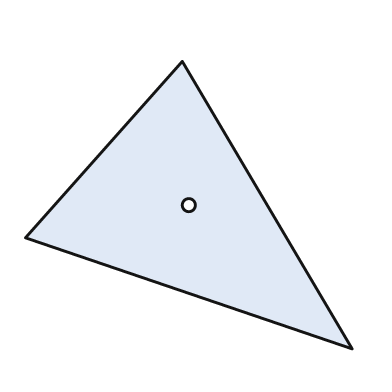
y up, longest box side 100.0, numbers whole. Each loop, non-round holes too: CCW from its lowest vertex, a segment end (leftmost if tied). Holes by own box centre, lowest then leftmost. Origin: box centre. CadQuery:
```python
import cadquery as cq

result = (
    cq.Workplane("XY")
    .moveTo(50.0, -44.0)
    .lineTo(-2.0, 44.0)
    .lineTo(-50.0, -10.0)
    .close()
    .moveTo(0.0, 0.0)
    .circle(2.0)
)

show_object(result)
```